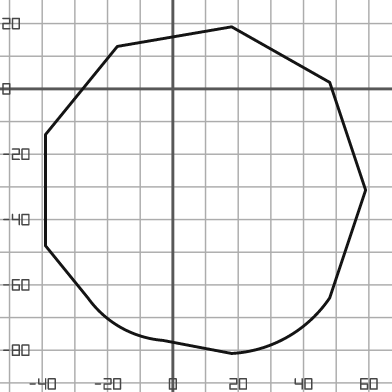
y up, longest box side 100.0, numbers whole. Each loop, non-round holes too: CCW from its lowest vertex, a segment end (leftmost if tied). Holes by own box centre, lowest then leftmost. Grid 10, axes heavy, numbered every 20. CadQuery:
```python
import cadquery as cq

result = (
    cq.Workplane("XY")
    .moveTo(18.0, -81.0)
    .threePointArc((35.0, -76.0), (48.0, -64.0))
    .lineTo(59.0, -31.0)
    .lineTo(48.0, 2.0)
    .lineTo(18.0, 19.0)
    .lineTo(-17.0, 13.0)
    .lineTo(-39.0, -14.0)
    .lineTo(-39.0, -48.0)
    .lineTo(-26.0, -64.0)
    .threePointArc((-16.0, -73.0), (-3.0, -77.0))
    .close()
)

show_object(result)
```